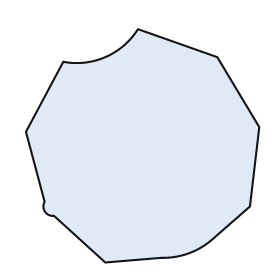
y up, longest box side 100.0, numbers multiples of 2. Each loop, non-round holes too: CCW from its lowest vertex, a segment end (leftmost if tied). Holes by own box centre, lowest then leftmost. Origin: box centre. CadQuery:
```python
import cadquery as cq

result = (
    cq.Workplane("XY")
    .moveTo(-16.0, -50.0)
    .lineTo(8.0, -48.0)
    .threePointArc((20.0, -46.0), (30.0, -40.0))
    .lineTo(46.0, -26.0)
    .lineTo(50.0, 8.0)
    .lineTo(32.0, 38.0)
    .lineTo(-2.0, 50.0)
    .threePointArc((-16.0, 38.0), (-34.0, 36.0))
    .lineTo(-50.0, 6.0)
    .lineTo(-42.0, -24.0)
    .threePointArc((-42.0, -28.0), (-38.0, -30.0))
    .close()
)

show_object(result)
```